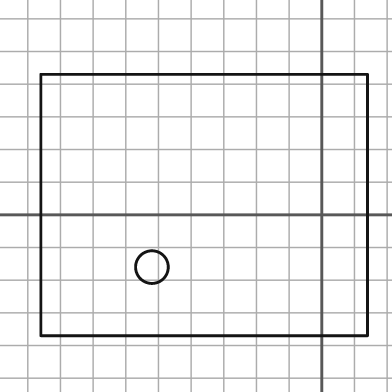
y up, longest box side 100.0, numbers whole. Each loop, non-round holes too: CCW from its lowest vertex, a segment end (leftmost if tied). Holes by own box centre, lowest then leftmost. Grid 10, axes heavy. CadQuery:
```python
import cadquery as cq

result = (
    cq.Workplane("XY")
    .moveTo(-86.0, -37.0)
    .lineTo(14.0, -37.0)
    .lineTo(14.0, 43.0)
    .lineTo(-86.0, 43.0)
    .close()
    .moveTo(-52.0, -16.0)
    .circle(5.0)
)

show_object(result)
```